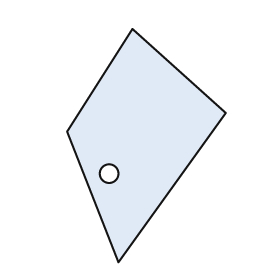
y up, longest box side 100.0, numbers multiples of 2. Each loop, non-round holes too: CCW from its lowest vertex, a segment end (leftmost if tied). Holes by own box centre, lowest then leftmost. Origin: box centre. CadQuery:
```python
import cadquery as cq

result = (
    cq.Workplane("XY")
    .moveTo(-12.0, -50.0)
    .lineTo(34.0, 14.0)
    .lineTo(-6.0, 50.0)
    .lineTo(-34.0, 6.0)
    .close()
    .moveTo(-16.0, -12.0)
    .circle(4.0)
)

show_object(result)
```